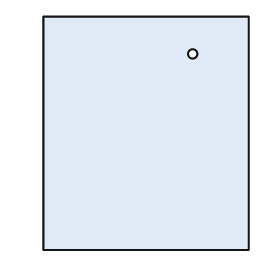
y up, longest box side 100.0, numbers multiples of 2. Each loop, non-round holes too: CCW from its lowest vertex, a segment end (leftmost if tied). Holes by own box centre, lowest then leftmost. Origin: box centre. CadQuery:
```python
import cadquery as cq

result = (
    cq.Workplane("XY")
    .moveTo(-44.0, -50.0)
    .lineTo(44.0, -50.0)
    .lineTo(44.0, 50.0)
    .lineTo(-44.0, 50.0)
    .close()
    .moveTo(20.0, 34.0)
    .circle(2.0)
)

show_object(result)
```